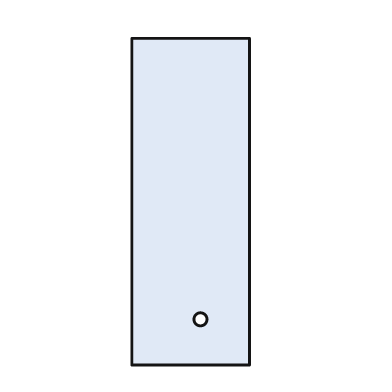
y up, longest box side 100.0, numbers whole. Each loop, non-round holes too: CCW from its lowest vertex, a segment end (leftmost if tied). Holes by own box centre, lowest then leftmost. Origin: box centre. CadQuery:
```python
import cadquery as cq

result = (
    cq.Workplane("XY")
    .moveTo(-18.0, -50.0)
    .lineTo(18.0, -50.0)
    .lineTo(18.0, 50.0)
    .lineTo(-18.0, 50.0)
    .close()
    .moveTo(3.0, -36.0)
    .circle(2.0)
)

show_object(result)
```